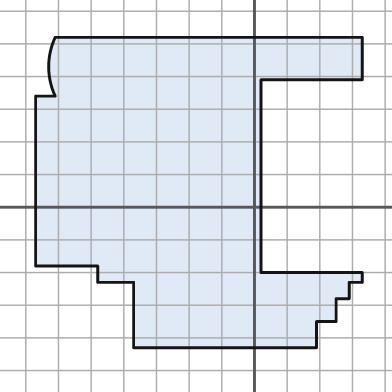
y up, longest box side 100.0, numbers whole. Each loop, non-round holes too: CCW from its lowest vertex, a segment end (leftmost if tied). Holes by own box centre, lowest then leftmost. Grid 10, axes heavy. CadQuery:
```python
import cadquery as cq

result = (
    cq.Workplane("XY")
    .moveTo(-37.0, -43.0)
    .lineTo(19.0, -43.0)
    .lineTo(19.0, -35.0)
    .lineTo(25.0, -35.0)
    .lineTo(25.0, -28.0)
    .lineTo(29.0, -28.0)
    .lineTo(29.0, -23.0)
    .lineTo(33.0, -23.0)
    .lineTo(33.0, -20.0)
    .lineTo(2.0, -20.0)
    .lineTo(2.0, 39.0)
    .lineTo(33.0, 39.0)
    .lineTo(33.0, 52.0)
    .lineTo(-61.0, 52.0)
    .threePointArc((-63.0, 43.0), (-61.0, 34.0))
    .lineTo(-67.0, 34.0)
    .lineTo(-67.0, -18.0)
    .lineTo(-48.0, -18.0)
    .lineTo(-48.0, -23.0)
    .lineTo(-37.0, -23.0)
    .close()
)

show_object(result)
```